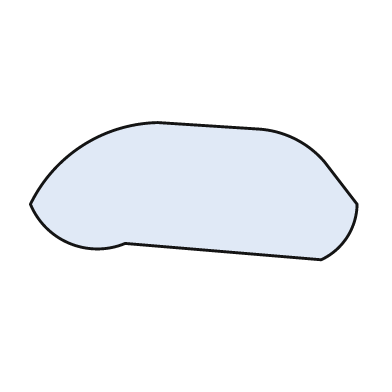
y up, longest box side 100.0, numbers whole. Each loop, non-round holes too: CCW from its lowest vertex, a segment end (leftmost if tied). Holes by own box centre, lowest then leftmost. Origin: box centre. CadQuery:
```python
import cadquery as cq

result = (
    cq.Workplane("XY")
    .moveTo(39.0, -21.0)
    .threePointArc((47.0, -14.0), (50.0, -4.0))
    .lineTo(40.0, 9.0)
    .threePointArc((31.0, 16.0), (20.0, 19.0))
    .lineTo(-11.0, 21.0)
    .threePointArc((-34.0, 14.0), (-50.0, -4.0))
    .threePointArc((-38.0, -16.0), (-21.0, -16.0))
    .close()
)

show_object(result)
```